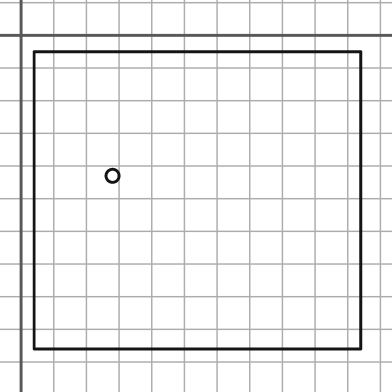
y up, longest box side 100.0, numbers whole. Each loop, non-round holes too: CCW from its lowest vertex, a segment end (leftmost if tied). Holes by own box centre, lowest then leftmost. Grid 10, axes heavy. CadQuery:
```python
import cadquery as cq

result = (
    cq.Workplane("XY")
    .moveTo(4.0, -96.0)
    .lineTo(104.0, -96.0)
    .lineTo(104.0, -5.0)
    .lineTo(4.0, -5.0)
    .close()
    .moveTo(28.0, -43.0)
    .circle(2.0)
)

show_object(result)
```